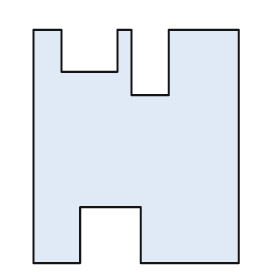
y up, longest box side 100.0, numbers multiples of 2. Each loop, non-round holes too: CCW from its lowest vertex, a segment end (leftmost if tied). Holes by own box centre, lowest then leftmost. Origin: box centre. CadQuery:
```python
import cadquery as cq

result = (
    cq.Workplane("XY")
    .moveTo(-44.0, -50.0)
    .lineTo(-24.0, -50.0)
    .lineTo(-24.0, -26.0)
    .lineTo(2.0, -26.0)
    .lineTo(2.0, -50.0)
    .lineTo(44.0, -50.0)
    .lineTo(44.0, 50.0)
    .lineTo(14.0, 50.0)
    .lineTo(14.0, 22.0)
    .lineTo(-2.0, 22.0)
    .lineTo(-2.0, 50.0)
    .lineTo(-8.0, 50.0)
    .lineTo(-8.0, 32.0)
    .lineTo(-32.0, 32.0)
    .lineTo(-32.0, 50.0)
    .lineTo(-44.0, 50.0)
    .close()
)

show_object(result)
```